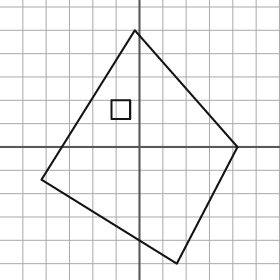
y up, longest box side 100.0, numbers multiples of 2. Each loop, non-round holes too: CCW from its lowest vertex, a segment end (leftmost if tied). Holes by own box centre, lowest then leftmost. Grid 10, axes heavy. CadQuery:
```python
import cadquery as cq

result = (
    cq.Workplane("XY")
    .moveTo(16.0, -50.0)
    .lineTo(42.0, 0.0)
    .lineTo(-2.0, 50.0)
    .lineTo(-42.0, -14.0)
    .close()
    .moveTo(-12.0, 12.0)
    .lineTo(-4.0, 12.0)
    .lineTo(-4.0, 20.0)
    .lineTo(-12.0, 20.0)
    .close()
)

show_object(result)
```